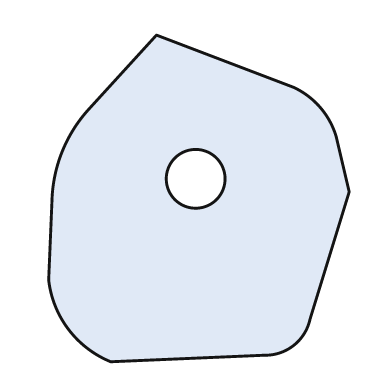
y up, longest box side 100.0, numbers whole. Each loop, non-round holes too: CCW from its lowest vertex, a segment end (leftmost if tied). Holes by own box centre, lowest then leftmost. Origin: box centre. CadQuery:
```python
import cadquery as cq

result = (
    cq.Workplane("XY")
    .moveTo(-27.0, -50.0)
    .lineTo(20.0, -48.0)
    .threePointArc((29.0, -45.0), (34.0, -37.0))
    .lineTo(46.0, 2.0)
    .lineTo(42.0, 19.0)
    .threePointArc((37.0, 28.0), (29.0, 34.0))
    .lineTo(-13.0, 50.0)
    .lineTo(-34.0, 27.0)
    .threePointArc((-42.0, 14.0), (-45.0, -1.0))
    .lineTo(-46.0, -25.0)
    .threePointArc((-40.0, -40.0), (-27.0, -50.0))
    .close()
    .moveTo(-1.0, 6.0)
    .circle(9.0)
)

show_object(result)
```